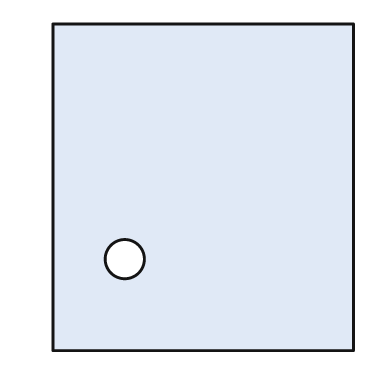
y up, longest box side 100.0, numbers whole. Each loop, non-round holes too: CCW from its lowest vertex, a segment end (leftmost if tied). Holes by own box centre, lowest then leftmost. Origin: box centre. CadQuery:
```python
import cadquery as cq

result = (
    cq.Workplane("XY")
    .moveTo(-46.0, -50.0)
    .lineTo(46.0, -50.0)
    .lineTo(46.0, 50.0)
    .lineTo(-46.0, 50.0)
    .close()
    .moveTo(-24.0, -22.0)
    .circle(6.0)
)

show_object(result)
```